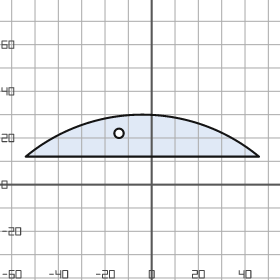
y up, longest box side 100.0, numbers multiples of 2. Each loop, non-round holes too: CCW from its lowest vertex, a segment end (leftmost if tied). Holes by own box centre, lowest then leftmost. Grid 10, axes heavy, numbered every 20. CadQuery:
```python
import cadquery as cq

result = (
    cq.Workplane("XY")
    .moveTo(-54.0, 12.0)
    .lineTo(46.0, 12.0)
    .threePointArc((-4.0, 30.0), (-54.0, 12.0))
    .close()
    .moveTo(-14.0, 22.0)
    .circle(2.0)
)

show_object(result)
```